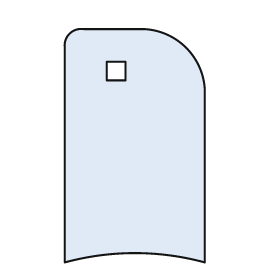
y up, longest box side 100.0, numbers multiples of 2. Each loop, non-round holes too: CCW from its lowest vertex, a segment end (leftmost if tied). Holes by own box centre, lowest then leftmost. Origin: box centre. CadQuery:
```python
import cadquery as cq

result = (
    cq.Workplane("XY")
    .moveTo(-30.0, -50.0)
    .threePointArc((0.0, -46.0), (30.0, -50.0))
    .lineTo(30.0, 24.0)
    .threePointArc((22.0, 42.0), (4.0, 50.0))
    .lineTo(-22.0, 50.0)
    .threePointArc((-28.0, 48.0), (-30.0, 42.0))
    .close()
    .moveTo(-12.0, 28.0)
    .lineTo(-4.0, 28.0)
    .lineTo(-4.0, 36.0)
    .lineTo(-12.0, 36.0)
    .close()
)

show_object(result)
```